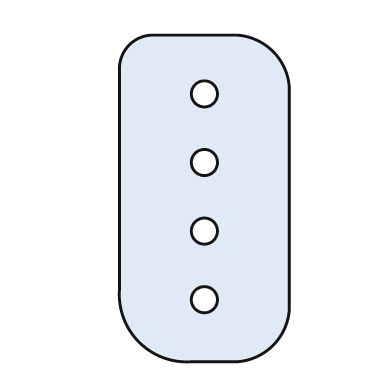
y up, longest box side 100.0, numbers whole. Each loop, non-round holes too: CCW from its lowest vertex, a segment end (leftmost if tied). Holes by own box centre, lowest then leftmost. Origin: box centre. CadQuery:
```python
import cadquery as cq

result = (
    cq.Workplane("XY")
    .moveTo(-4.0, -50.0)
    .lineTo(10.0, -50.0)
    .threePointArc((21.0, -45.0), (26.0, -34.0))
    .lineTo(26.0, 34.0)
    .threePointArc((21.0, 45.0), (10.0, 50.0))
    .lineTo(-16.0, 50.0)
    .threePointArc((-23.0, 47.0), (-26.0, 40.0))
    .lineTo(-26.0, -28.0)
    .threePointArc((-20.0, -44.0), (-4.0, -50.0))
    .close()
    .moveTo(0.0, -31.0)
    .circle(4.0)
    .moveTo(0.0, -10.0)
    .circle(4.0)
    .moveTo(0.0, 11.0)
    .circle(4.0)
    .moveTo(0.0, 32.0)
    .circle(4.0)
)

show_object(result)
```